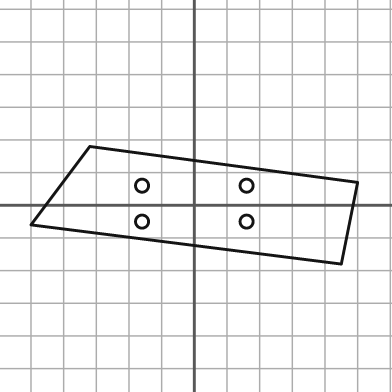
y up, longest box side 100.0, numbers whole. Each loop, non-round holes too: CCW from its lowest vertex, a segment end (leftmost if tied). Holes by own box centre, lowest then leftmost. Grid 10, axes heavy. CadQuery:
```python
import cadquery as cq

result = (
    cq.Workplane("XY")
    .moveTo(45.0, -18.0)
    .lineTo(50.0, 7.0)
    .lineTo(-32.0, 18.0)
    .lineTo(-50.0, -6.0)
    .close()
    .moveTo(-16.0, -5.0)
    .circle(2.0)
    .moveTo(16.0, -5.0)
    .circle(2.0)
    .moveTo(-16.0, 6.0)
    .circle(2.0)
    .moveTo(16.0, 6.0)
    .circle(2.0)
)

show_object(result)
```